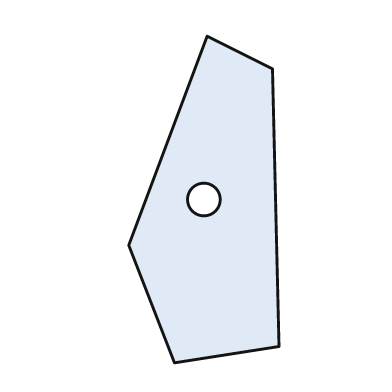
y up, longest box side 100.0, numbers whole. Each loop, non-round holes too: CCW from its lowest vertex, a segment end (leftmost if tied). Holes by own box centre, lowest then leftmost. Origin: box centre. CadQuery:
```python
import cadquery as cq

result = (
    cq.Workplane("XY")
    .moveTo(-9.0, -50.0)
    .lineTo(23.0, -45.0)
    .lineTo(21.0, 40.0)
    .lineTo(1.0, 50.0)
    .lineTo(-23.0, -14.0)
    .close()
    .moveTo(0.0, 0.0)
    .circle(5.0)
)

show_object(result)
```